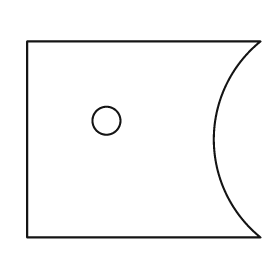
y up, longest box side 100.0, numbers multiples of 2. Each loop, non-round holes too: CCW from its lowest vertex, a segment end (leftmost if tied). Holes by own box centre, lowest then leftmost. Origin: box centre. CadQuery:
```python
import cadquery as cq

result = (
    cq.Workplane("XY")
    .moveTo(-50.0, -42.0)
    .lineTo(50.0, -42.0)
    .threePointArc((30.0, 0.0), (50.0, 42.0))
    .lineTo(-50.0, 42.0)
    .close()
    .moveTo(-16.0, 8.0)
    .circle(6.0)
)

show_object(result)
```